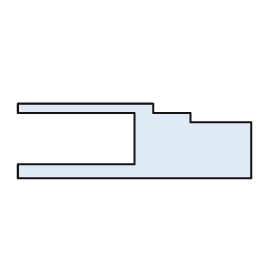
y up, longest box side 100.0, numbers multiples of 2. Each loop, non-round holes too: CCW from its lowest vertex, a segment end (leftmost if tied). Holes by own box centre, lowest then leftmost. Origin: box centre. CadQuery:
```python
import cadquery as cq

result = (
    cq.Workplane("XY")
    .moveTo(-50.0, -16.0)
    .lineTo(50.0, -16.0)
    .lineTo(50.0, 8.0)
    .lineTo(24.0, 8.0)
    .lineTo(24.0, 12.0)
    .lineTo(8.0, 12.0)
    .lineTo(8.0, 16.0)
    .lineTo(-50.0, 16.0)
    .lineTo(-50.0, 12.0)
    .lineTo(0.0, 12.0)
    .lineTo(0.0, -10.0)
    .lineTo(-50.0, -10.0)
    .close()
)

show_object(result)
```